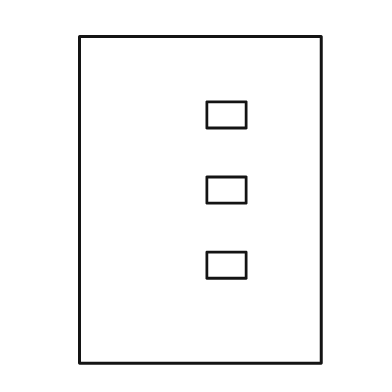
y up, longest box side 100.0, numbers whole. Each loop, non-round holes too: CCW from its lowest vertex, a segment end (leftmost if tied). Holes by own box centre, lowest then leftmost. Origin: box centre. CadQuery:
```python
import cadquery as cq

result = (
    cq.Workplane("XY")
    .moveTo(-37.0, -50.0)
    .lineTo(37.0, -50.0)
    .lineTo(37.0, 50.0)
    .lineTo(-37.0, 50.0)
    .close()
    .moveTo(2.0, -24.0)
    .lineTo(14.0, -24.0)
    .lineTo(14.0, -16.0)
    .lineTo(2.0, -16.0)
    .close()
    .moveTo(2.0, -1.0)
    .lineTo(14.0, -1.0)
    .lineTo(14.0, 7.0)
    .lineTo(2.0, 7.0)
    .close()
    .moveTo(2.0, 22.0)
    .lineTo(14.0, 22.0)
    .lineTo(14.0, 30.0)
    .lineTo(2.0, 30.0)
    .close()
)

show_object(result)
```